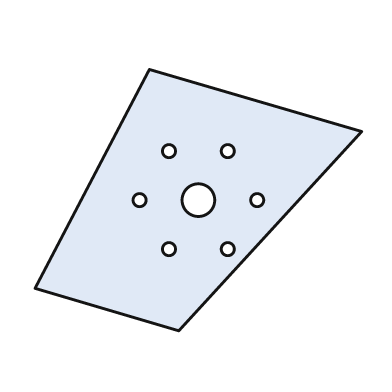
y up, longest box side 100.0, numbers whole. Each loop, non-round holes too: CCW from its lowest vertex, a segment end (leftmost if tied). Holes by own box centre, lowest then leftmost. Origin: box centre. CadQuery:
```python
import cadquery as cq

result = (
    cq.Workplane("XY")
    .moveTo(-6.0, -40.0)
    .lineTo(50.0, 21.0)
    .lineTo(-15.0, 40.0)
    .lineTo(-50.0, -27.0)
    .close()
    .moveTo(-9.0, -15.0)
    .circle(2.0)
    .moveTo(9.0, -15.0)
    .circle(2.0)
    .moveTo(-18.0, 0.0)
    .circle(2.0)
    .moveTo(0.0, 0.0)
    .circle(5.0)
    .moveTo(18.0, 0.0)
    .circle(2.0)
    .moveTo(-9.0, 15.0)
    .circle(2.0)
    .moveTo(9.0, 15.0)
    .circle(2.0)
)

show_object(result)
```